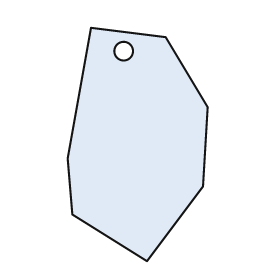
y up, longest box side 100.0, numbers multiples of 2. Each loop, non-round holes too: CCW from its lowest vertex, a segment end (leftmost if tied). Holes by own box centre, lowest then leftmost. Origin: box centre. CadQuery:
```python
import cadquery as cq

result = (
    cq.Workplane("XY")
    .moveTo(4.0, -50.0)
    .lineTo(28.0, -18.0)
    .lineTo(30.0, 16.0)
    .lineTo(12.0, 46.0)
    .lineTo(-20.0, 50.0)
    .lineTo(-30.0, -6.0)
    .lineTo(-28.0, -30.0)
    .close()
    .moveTo(-6.0, 40.0)
    .circle(4.0)
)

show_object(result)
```